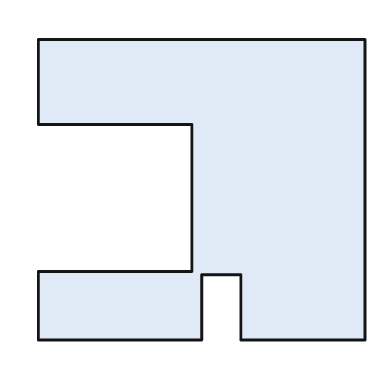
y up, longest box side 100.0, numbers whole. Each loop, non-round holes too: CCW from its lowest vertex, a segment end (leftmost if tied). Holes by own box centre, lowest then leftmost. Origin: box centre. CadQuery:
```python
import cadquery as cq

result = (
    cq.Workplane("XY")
    .moveTo(-50.0, -46.0)
    .lineTo(0.0, -46.0)
    .lineTo(0.0, -26.0)
    .lineTo(12.0, -26.0)
    .lineTo(12.0, -46.0)
    .lineTo(50.0, -46.0)
    .lineTo(50.0, 46.0)
    .lineTo(-50.0, 46.0)
    .lineTo(-50.0, 20.0)
    .lineTo(-3.0, 20.0)
    .lineTo(-3.0, -25.0)
    .lineTo(-50.0, -25.0)
    .close()
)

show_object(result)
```